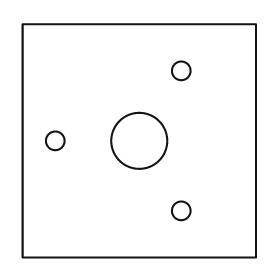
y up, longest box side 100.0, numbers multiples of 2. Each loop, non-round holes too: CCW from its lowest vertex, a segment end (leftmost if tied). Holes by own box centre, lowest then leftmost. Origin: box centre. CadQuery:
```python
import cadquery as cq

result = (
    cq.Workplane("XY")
    .moveTo(-50.0, -50.0)
    .lineTo(50.0, -50.0)
    .lineTo(50.0, 50.0)
    .lineTo(-50.0, 50.0)
    .close()
    .moveTo(18.0, -30.0)
    .circle(4.0)
    .moveTo(-36.0, 0.0)
    .circle(4.0)
    .moveTo(0.0, 0.0)
    .circle(12.0)
    .moveTo(18.0, 30.0)
    .circle(4.0)
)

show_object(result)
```